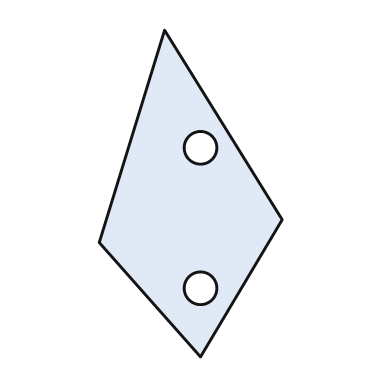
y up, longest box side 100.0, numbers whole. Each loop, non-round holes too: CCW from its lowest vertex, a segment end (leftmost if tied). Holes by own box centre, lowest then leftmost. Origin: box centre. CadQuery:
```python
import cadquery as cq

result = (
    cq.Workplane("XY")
    .moveTo(3.0, -50.0)
    .lineTo(28.0, -8.0)
    .lineTo(-8.0, 50.0)
    .lineTo(-28.0, -15.0)
    .close()
    .moveTo(3.0, -29.0)
    .circle(5.0)
    .moveTo(3.0, 14.0)
    .circle(5.0)
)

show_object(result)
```